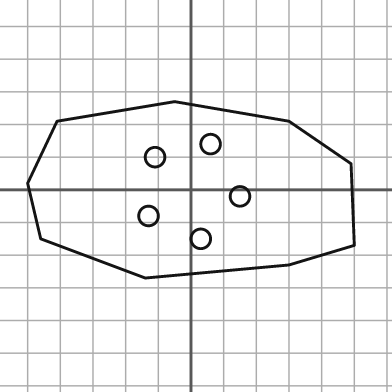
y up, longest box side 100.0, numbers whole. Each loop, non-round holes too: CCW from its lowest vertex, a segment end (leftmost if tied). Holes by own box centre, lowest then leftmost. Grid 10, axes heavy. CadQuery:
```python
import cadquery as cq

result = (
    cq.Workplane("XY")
    .moveTo(-14.0, -27.0)
    .lineTo(30.0, -23.0)
    .lineTo(50.0, -17.0)
    .lineTo(49.0, 8.0)
    .lineTo(30.0, 21.0)
    .lineTo(-5.0, 27.0)
    .lineTo(-41.0, 21.0)
    .lineTo(-50.0, 2.0)
    .lineTo(-46.0, -15.0)
    .close()
    .moveTo(3.0, -15.0)
    .circle(3.0)
    .moveTo(-13.0, -8.0)
    .circle(3.0)
    .moveTo(15.0, -2.0)
    .circle(3.0)
    .moveTo(-11.0, 10.0)
    .circle(3.0)
    .moveTo(6.0, 14.0)
    .circle(3.0)
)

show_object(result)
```